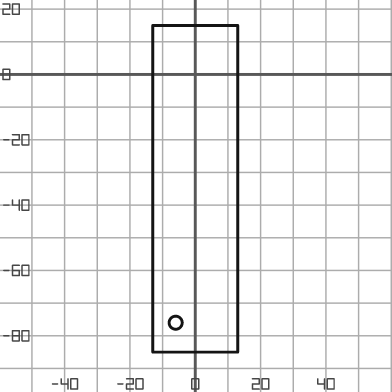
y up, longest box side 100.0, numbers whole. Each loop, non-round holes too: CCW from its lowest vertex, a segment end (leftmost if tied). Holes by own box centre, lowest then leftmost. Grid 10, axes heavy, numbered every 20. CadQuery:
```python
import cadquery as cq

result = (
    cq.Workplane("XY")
    .moveTo(-13.0, -85.0)
    .lineTo(13.0, -85.0)
    .lineTo(13.0, 15.0)
    .lineTo(-13.0, 15.0)
    .close()
    .moveTo(-6.0, -76.0)
    .circle(2.0)
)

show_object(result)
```